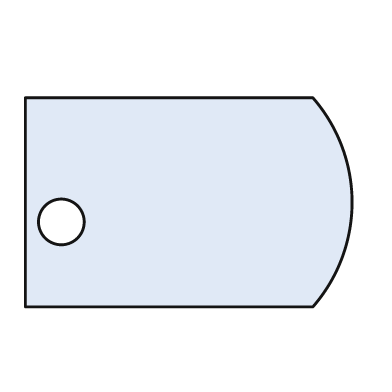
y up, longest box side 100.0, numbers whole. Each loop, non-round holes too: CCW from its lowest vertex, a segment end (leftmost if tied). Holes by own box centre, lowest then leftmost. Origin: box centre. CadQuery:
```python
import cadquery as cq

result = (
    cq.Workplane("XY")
    .moveTo(-50.0, -32.0)
    .lineTo(38.0, -32.0)
    .threePointArc((50.0, 0.0), (38.0, 32.0))
    .lineTo(-50.0, 32.0)
    .close()
    .moveTo(-39.0, -6.0)
    .circle(7.0)
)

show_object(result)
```